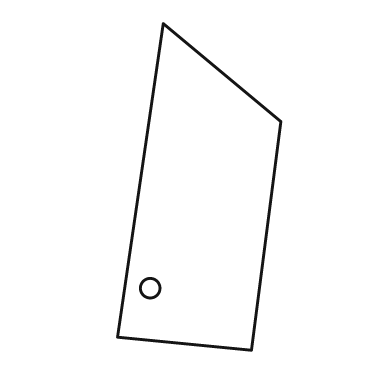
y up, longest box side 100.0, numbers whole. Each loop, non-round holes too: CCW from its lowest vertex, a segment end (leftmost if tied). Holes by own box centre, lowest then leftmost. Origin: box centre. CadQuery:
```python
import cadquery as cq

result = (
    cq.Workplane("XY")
    .moveTo(16.0, -50.0)
    .lineTo(25.0, 20.0)
    .lineTo(-11.0, 50.0)
    .lineTo(-25.0, -46.0)
    .close()
    .moveTo(-15.0, -31.0)
    .circle(3.0)
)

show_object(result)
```